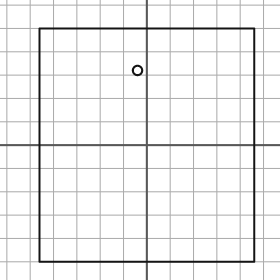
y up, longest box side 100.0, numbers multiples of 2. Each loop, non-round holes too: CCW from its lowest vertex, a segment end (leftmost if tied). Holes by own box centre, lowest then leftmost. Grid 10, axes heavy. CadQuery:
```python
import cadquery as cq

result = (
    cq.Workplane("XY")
    .moveTo(-46.0, -50.0)
    .lineTo(46.0, -50.0)
    .lineTo(46.0, 50.0)
    .lineTo(-46.0, 50.0)
    .close()
    .moveTo(-4.0, 32.0)
    .circle(2.0)
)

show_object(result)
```